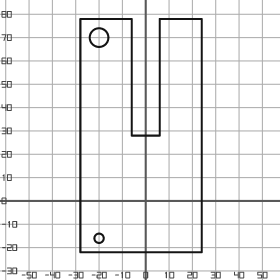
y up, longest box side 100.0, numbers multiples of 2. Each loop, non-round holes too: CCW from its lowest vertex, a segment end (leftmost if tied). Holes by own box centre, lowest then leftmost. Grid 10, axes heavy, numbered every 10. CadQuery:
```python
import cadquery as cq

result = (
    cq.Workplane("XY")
    .moveTo(-28.0, -22.0)
    .lineTo(24.0, -22.0)
    .lineTo(24.0, 78.0)
    .lineTo(6.0, 78.0)
    .lineTo(6.0, 28.0)
    .lineTo(-6.0, 28.0)
    .lineTo(-6.0, 78.0)
    .lineTo(-28.0, 78.0)
    .close()
    .moveTo(-20.0, -16.0)
    .circle(2.0)
    .moveTo(-20.0, 70.0)
    .circle(4.0)
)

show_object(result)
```